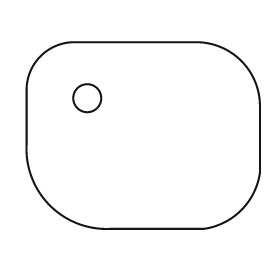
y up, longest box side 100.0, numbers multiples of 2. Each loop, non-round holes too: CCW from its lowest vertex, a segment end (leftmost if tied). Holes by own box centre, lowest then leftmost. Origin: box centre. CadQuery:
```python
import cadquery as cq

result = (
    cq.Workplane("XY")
    .moveTo(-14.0, -40.0)
    .lineTo(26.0, -40.0)
    .threePointArc((42.0, -32.0), (50.0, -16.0))
    .lineTo(50.0, 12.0)
    .threePointArc((42.0, 32.0), (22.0, 40.0))
    .lineTo(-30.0, 40.0)
    .threePointArc((-44.0, 34.0), (-50.0, 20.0))
    .lineTo(-50.0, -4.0)
    .threePointArc((-40.0, -30.0), (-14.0, -40.0))
    .close()
    .moveTo(-24.0, 16.0)
    .circle(6.0)
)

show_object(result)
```